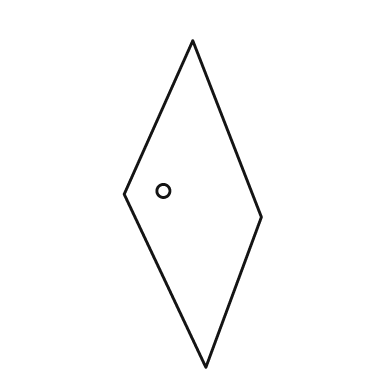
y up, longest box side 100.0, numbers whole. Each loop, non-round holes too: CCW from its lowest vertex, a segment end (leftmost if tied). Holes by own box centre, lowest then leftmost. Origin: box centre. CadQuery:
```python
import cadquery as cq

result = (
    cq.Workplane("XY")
    .moveTo(4.0, -50.0)
    .lineTo(21.0, -4.0)
    .lineTo(0.0, 50.0)
    .lineTo(-21.0, 3.0)
    .close()
    .moveTo(-9.0, 4.0)
    .circle(2.0)
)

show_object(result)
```